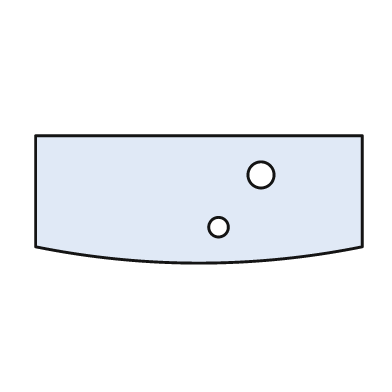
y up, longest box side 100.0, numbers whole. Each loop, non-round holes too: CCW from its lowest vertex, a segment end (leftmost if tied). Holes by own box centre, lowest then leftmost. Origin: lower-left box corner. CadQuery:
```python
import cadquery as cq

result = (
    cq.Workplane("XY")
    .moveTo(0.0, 5.0)
    .threePointArc((50.0, 0.0), (100.0, 5.0))
    .lineTo(100.0, 39.0)
    .lineTo(0.0, 39.0)
    .close()
    .moveTo(56.0, 11.0)
    .circle(3.0)
    .moveTo(69.0, 27.0)
    .circle(4.0)
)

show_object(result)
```